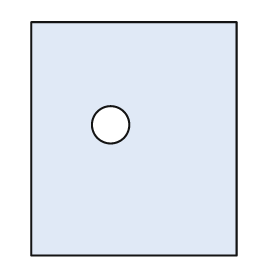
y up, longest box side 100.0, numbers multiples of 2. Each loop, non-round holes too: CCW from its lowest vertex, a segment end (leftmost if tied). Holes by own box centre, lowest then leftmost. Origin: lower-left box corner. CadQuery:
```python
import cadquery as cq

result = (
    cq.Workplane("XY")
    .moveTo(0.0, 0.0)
    .lineTo(88.0, 0.0)
    .lineTo(88.0, 100.0)
    .lineTo(0.0, 100.0)
    .close()
    .moveTo(34.0, 56.0)
    .circle(8.0)
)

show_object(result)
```